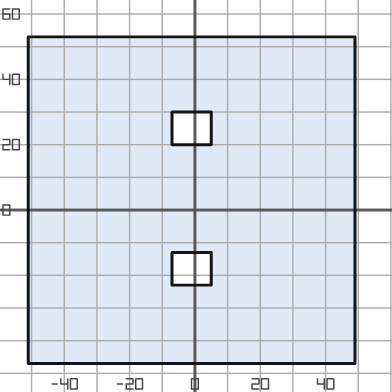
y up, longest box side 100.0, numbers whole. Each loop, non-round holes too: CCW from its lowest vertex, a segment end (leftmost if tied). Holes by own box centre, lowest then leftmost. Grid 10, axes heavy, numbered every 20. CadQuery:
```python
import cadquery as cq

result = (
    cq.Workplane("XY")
    .moveTo(-51.0, -47.0)
    .lineTo(49.0, -47.0)
    .lineTo(49.0, 53.0)
    .lineTo(-51.0, 53.0)
    .close()
    .moveTo(-7.0, -23.0)
    .lineTo(5.0, -23.0)
    .lineTo(5.0, -13.0)
    .lineTo(-7.0, -13.0)
    .close()
    .moveTo(-7.0, 20.0)
    .lineTo(5.0, 20.0)
    .lineTo(5.0, 30.0)
    .lineTo(-7.0, 30.0)
    .close()
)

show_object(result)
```